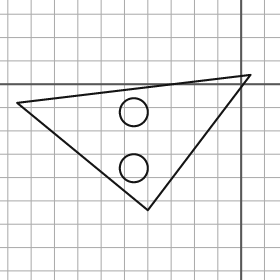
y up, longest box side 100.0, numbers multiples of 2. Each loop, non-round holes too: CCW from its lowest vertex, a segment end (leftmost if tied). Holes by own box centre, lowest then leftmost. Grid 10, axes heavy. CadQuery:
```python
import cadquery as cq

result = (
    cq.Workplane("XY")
    .moveTo(-40.0, -54.0)
    .lineTo(4.0, 4.0)
    .lineTo(-96.0, -8.0)
    .close()
    .moveTo(-46.0, -36.0)
    .circle(6.0)
    .moveTo(-46.0, -12.0)
    .circle(6.0)
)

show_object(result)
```